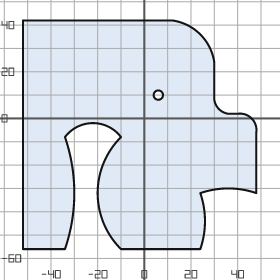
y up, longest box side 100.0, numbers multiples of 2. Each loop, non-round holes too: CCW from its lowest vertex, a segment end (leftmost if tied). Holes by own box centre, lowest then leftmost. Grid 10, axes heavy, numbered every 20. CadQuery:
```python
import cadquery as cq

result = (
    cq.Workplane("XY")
    .moveTo(-52.0, -56.0)
    .lineTo(-34.0, -56.0)
    .threePointArc((-30.0, -32.0), (-34.0, -8.0))
    .threePointArc((-22.0, -2.0), (-10.0, -8.0))
    .threePointArc((-20.0, -32.0), (-10.0, -56.0))
    .lineTo(24.0, -56.0)
    .threePointArc((26.0, -44.0), (24.0, -32.0))
    .threePointArc((36.0, -30.0), (48.0, -32.0))
    .lineTo(48.0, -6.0)
    .threePointArc((46.0, 0.0), (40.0, 2.0))
    .lineTo(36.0, 2.0)
    .threePointArc((32.0, 4.0), (30.0, 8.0))
    .lineTo(30.0, 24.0)
    .threePointArc((24.0, 36.0), (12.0, 42.0))
    .lineTo(-52.0, 42.0)
    .close()
    .moveTo(6.0, 10.0)
    .circle(2.0)
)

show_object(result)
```